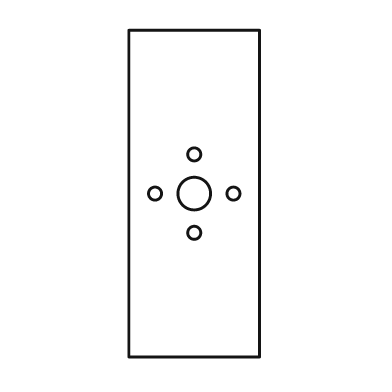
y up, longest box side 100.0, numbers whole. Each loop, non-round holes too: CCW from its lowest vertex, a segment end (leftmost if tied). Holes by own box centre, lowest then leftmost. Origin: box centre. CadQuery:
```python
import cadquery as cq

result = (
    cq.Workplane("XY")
    .moveTo(-20.0, -50.0)
    .lineTo(20.0, -50.0)
    .lineTo(20.0, 50.0)
    .lineTo(-20.0, 50.0)
    .close()
    .moveTo(0.0, -12.0)
    .circle(2.0)
    .moveTo(-12.0, 0.0)
    .circle(2.0)
    .moveTo(0.0, 0.0)
    .circle(5.0)
    .moveTo(12.0, 0.0)
    .circle(2.0)
    .moveTo(0.0, 12.0)
    .circle(2.0)
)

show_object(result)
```